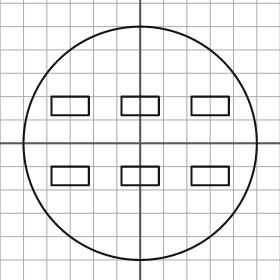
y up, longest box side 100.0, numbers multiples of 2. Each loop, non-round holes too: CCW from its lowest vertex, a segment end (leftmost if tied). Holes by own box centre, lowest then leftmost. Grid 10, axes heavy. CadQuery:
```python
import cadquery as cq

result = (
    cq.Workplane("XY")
    .moveTo(0.0, 0.0)
    .circle(50.0)
    .moveTo(-38.0, -18.0)
    .lineTo(-22.0, -18.0)
    .lineTo(-22.0, -10.0)
    .lineTo(-38.0, -10.0)
    .close()
    .moveTo(-8.0, -18.0)
    .lineTo(8.0, -18.0)
    .lineTo(8.0, -10.0)
    .lineTo(-8.0, -10.0)
    .close()
    .moveTo(22.0, -18.0)
    .lineTo(38.0, -18.0)
    .lineTo(38.0, -10.0)
    .lineTo(22.0, -10.0)
    .close()
    .moveTo(-38.0, 12.0)
    .lineTo(-22.0, 12.0)
    .lineTo(-22.0, 20.0)
    .lineTo(-38.0, 20.0)
    .close()
    .moveTo(-8.0, 12.0)
    .lineTo(8.0, 12.0)
    .lineTo(8.0, 20.0)
    .lineTo(-8.0, 20.0)
    .close()
    .moveTo(22.0, 12.0)
    .lineTo(38.0, 12.0)
    .lineTo(38.0, 20.0)
    .lineTo(22.0, 20.0)
    .close()
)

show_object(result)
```